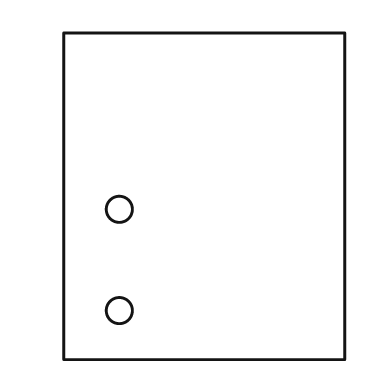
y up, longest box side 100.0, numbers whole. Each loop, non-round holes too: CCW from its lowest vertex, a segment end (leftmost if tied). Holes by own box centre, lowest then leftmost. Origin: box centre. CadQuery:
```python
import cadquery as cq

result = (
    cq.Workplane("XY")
    .moveTo(-43.0, -50.0)
    .lineTo(43.0, -50.0)
    .lineTo(43.0, 50.0)
    .lineTo(-43.0, 50.0)
    .close()
    .moveTo(-26.0, -35.0)
    .circle(4.0)
    .moveTo(-26.0, -4.0)
    .circle(4.0)
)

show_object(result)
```